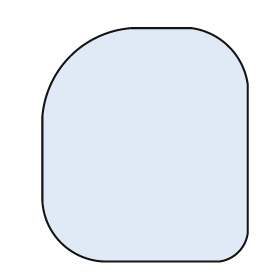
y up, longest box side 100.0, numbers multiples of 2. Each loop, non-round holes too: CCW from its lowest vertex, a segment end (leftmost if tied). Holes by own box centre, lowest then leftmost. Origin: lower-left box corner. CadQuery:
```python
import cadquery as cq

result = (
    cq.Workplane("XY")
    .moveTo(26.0, 0.0)
    .lineTo(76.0, 0.0)
    .threePointArc((84.0, 4.0), (88.0, 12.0))
    .lineTo(88.0, 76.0)
    .threePointArc((80.0, 92.0), (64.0, 100.0))
    .lineTo(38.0, 100.0)
    .threePointArc((12.0, 88.0), (0.0, 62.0))
    .lineTo(0.0, 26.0)
    .threePointArc((8.0, 8.0), (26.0, 0.0))
    .close()
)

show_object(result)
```